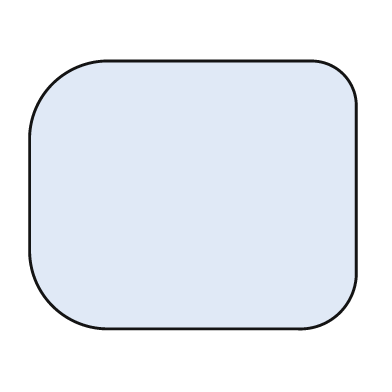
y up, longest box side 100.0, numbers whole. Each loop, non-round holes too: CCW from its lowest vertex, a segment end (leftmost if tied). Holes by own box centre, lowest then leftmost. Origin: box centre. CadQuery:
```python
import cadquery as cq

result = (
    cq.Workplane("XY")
    .moveTo(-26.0, -41.0)
    .lineTo(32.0, -41.0)
    .threePointArc((45.0, -36.0), (50.0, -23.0))
    .lineTo(50.0, 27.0)
    .threePointArc((46.0, 37.0), (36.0, 41.0))
    .lineTo(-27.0, 41.0)
    .threePointArc((-43.0, 34.0), (-50.0, 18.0))
    .lineTo(-50.0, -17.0)
    .threePointArc((-43.0, -34.0), (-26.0, -41.0))
    .close()
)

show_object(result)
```